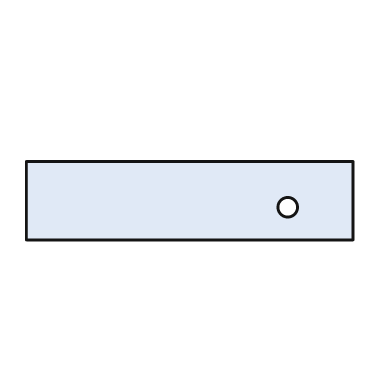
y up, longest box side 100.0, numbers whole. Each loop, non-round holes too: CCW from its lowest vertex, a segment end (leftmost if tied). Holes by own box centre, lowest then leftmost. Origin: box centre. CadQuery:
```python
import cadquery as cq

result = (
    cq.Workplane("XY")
    .moveTo(-50.0, -12.0)
    .lineTo(50.0, -12.0)
    .lineTo(50.0, 12.0)
    .lineTo(-50.0, 12.0)
    .close()
    .moveTo(30.0, -2.0)
    .circle(3.0)
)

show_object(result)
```